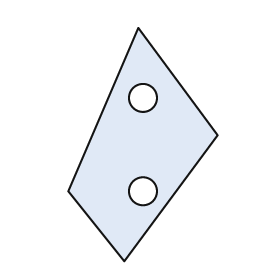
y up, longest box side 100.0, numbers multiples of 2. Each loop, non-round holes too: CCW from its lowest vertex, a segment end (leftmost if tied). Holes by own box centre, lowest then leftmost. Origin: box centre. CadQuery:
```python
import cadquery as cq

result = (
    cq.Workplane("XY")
    .moveTo(-8.0, -50.0)
    .lineTo(32.0, 4.0)
    .lineTo(-2.0, 50.0)
    .lineTo(-32.0, -20.0)
    .close()
    .moveTo(0.0, -20.0)
    .circle(6.0)
    .moveTo(0.0, 20.0)
    .circle(6.0)
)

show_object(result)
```